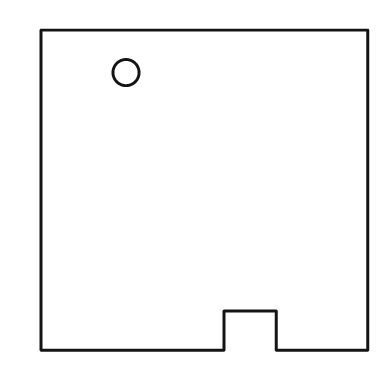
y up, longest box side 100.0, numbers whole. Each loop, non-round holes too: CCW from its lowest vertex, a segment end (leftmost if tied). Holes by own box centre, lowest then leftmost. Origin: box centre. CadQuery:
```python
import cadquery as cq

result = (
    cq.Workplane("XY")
    .moveTo(-50.0, -49.0)
    .lineTo(6.0, -49.0)
    .lineTo(6.0, -37.0)
    .lineTo(22.0, -37.0)
    .lineTo(22.0, -49.0)
    .lineTo(50.0, -49.0)
    .lineTo(50.0, 49.0)
    .lineTo(-50.0, 49.0)
    .close()
    .moveTo(-24.0, 36.0)
    .circle(4.0)
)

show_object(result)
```